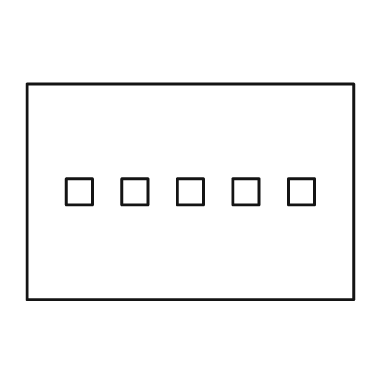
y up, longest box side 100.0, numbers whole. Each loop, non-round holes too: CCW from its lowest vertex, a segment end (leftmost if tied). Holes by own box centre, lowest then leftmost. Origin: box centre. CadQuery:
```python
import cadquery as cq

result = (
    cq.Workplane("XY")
    .moveTo(-50.0, -33.0)
    .lineTo(50.0, -33.0)
    .lineTo(50.0, 33.0)
    .lineTo(-50.0, 33.0)
    .close()
    .moveTo(-38.0, -4.0)
    .lineTo(-30.0, -4.0)
    .lineTo(-30.0, 4.0)
    .lineTo(-38.0, 4.0)
    .close()
    .moveTo(-21.0, -4.0)
    .lineTo(-13.0, -4.0)
    .lineTo(-13.0, 4.0)
    .lineTo(-21.0, 4.0)
    .close()
    .moveTo(-4.0, -4.0)
    .lineTo(4.0, -4.0)
    .lineTo(4.0, 4.0)
    .lineTo(-4.0, 4.0)
    .close()
    .moveTo(13.0, -4.0)
    .lineTo(21.0, -4.0)
    .lineTo(21.0, 4.0)
    .lineTo(13.0, 4.0)
    .close()
    .moveTo(30.0, -4.0)
    .lineTo(38.0, -4.0)
    .lineTo(38.0, 4.0)
    .lineTo(30.0, 4.0)
    .close()
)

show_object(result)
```